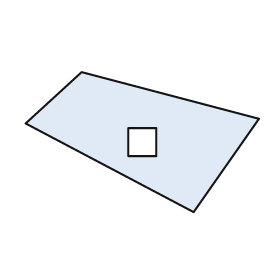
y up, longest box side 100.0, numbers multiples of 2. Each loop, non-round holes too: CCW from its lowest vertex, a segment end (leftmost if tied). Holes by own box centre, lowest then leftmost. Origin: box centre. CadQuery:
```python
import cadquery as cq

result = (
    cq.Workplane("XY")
    .moveTo(22.0, -30.0)
    .lineTo(50.0, 10.0)
    .lineTo(-26.0, 30.0)
    .lineTo(-50.0, 8.0)
    .close()
    .moveTo(-6.0, -6.0)
    .lineTo(6.0, -6.0)
    .lineTo(6.0, 6.0)
    .lineTo(-6.0, 6.0)
    .close()
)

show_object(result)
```